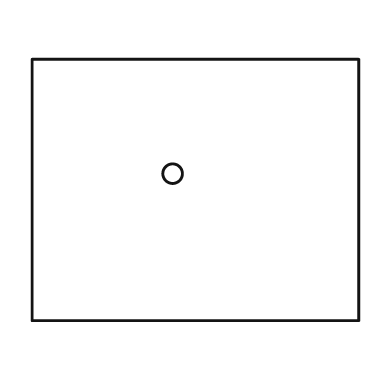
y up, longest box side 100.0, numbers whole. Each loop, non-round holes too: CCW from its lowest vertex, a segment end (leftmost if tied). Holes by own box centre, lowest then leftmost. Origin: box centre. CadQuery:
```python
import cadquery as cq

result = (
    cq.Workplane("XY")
    .moveTo(-50.0, -40.0)
    .lineTo(50.0, -40.0)
    .lineTo(50.0, 40.0)
    .lineTo(-50.0, 40.0)
    .close()
    .moveTo(-7.0, 5.0)
    .circle(3.0)
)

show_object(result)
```